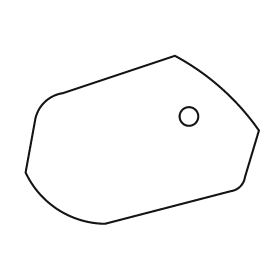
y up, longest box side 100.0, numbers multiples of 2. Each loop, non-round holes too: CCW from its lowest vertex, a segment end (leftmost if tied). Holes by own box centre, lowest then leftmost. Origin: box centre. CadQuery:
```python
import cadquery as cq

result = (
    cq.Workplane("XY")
    .moveTo(-16.0, -36.0)
    .lineTo(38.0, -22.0)
    .threePointArc((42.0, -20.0), (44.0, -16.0))
    .lineTo(50.0, 4.0)
    .threePointArc((34.0, 22.0), (14.0, 36.0))
    .lineTo(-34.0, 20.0)
    .threePointArc((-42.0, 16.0), (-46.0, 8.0))
    .lineTo(-50.0, -14.0)
    .threePointArc((-36.0, -30.0), (-16.0, -36.0))
    .close()
    .moveTo(20.0, 10.0)
    .circle(4.0)
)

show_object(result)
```